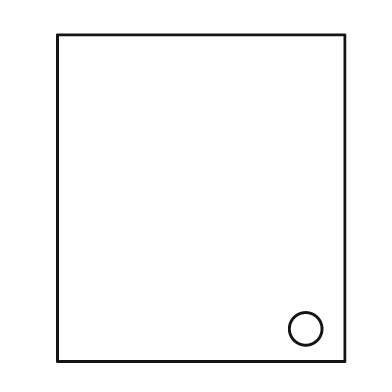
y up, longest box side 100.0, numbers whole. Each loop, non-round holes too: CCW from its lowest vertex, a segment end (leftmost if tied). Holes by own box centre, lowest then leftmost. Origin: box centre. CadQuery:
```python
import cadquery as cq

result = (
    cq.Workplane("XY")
    .moveTo(-44.0, -50.0)
    .lineTo(44.0, -50.0)
    .lineTo(44.0, 50.0)
    .lineTo(-44.0, 50.0)
    .close()
    .moveTo(32.0, -40.0)
    .circle(5.0)
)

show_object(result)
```